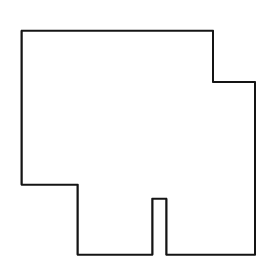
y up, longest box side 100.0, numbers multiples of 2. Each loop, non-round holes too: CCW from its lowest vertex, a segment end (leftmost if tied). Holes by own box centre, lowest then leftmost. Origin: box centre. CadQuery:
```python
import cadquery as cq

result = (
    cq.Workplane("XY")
    .moveTo(-26.0, -48.0)
    .lineTo(6.0, -48.0)
    .lineTo(6.0, -24.0)
    .lineTo(12.0, -24.0)
    .lineTo(12.0, -48.0)
    .lineTo(50.0, -48.0)
    .lineTo(50.0, 26.0)
    .lineTo(32.0, 26.0)
    .lineTo(32.0, 48.0)
    .lineTo(-50.0, 48.0)
    .lineTo(-50.0, -18.0)
    .lineTo(-26.0, -18.0)
    .close()
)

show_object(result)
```